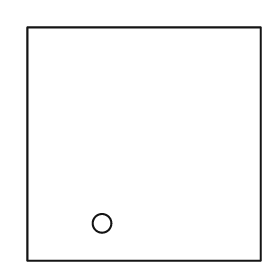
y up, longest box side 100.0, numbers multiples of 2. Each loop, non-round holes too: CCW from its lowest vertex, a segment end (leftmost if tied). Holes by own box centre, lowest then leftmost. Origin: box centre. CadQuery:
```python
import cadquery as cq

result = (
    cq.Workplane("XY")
    .moveTo(-50.0, -50.0)
    .lineTo(50.0, -50.0)
    .lineTo(50.0, 50.0)
    .lineTo(-50.0, 50.0)
    .close()
    .moveTo(-18.0, -34.0)
    .circle(4.0)
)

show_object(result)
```